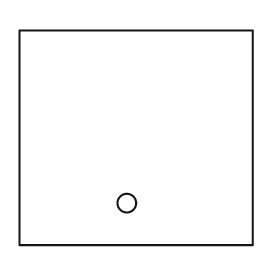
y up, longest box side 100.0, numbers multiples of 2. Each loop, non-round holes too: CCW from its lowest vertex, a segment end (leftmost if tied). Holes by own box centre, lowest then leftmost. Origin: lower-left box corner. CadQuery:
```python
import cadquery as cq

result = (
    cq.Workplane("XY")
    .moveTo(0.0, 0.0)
    .lineTo(100.0, 0.0)
    .lineTo(100.0, 92.0)
    .lineTo(0.0, 92.0)
    .close()
    .moveTo(46.0, 18.0)
    .circle(4.0)
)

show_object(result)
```